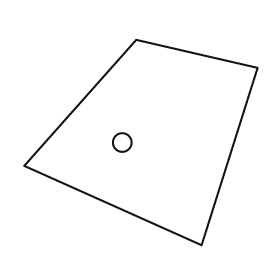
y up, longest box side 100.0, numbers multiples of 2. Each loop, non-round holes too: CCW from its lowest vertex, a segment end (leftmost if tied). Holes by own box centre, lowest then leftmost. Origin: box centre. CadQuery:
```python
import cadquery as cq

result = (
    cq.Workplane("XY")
    .moveTo(26.0, -44.0)
    .lineTo(50.0, 32.0)
    .lineTo(-2.0, 44.0)
    .lineTo(-50.0, -10.0)
    .close()
    .moveTo(-8.0, 0.0)
    .circle(4.0)
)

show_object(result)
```